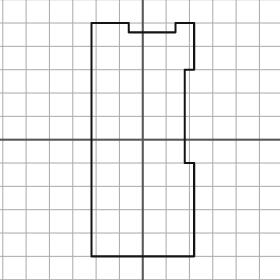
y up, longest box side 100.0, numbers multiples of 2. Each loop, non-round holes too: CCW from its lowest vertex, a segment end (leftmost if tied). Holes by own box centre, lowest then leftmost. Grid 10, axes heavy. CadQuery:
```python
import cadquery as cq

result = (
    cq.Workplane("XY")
    .moveTo(-22.0, -50.0)
    .lineTo(22.0, -50.0)
    .lineTo(22.0, -10.0)
    .lineTo(18.0, -10.0)
    .lineTo(18.0, 30.0)
    .lineTo(22.0, 30.0)
    .lineTo(22.0, 50.0)
    .lineTo(14.0, 50.0)
    .lineTo(14.0, 46.0)
    .lineTo(-6.0, 46.0)
    .lineTo(-6.0, 50.0)
    .lineTo(-22.0, 50.0)
    .close()
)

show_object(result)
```